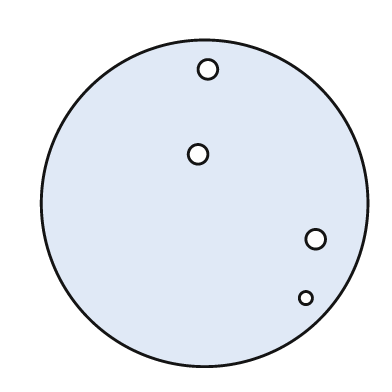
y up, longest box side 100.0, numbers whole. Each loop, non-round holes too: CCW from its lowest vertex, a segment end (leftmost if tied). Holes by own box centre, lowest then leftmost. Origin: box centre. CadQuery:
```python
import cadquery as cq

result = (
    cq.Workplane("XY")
    .moveTo(0.0, 0.0)
    .circle(50.0)
    .moveTo(31.0, -29.0)
    .circle(2.0)
    .moveTo(34.0, -11.0)
    .circle(3.0)
    .moveTo(-2.0, 15.0)
    .circle(3.0)
    .moveTo(1.0, 41.0)
    .circle(3.0)
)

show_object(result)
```